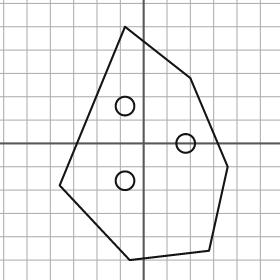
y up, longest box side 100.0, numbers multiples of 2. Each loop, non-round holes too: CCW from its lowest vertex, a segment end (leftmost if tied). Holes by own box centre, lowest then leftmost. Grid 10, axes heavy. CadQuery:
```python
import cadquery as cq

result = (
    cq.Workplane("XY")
    .moveTo(-6.0, -50.0)
    .lineTo(28.0, -46.0)
    .lineTo(36.0, -10.0)
    .lineTo(20.0, 28.0)
    .lineTo(-8.0, 50.0)
    .lineTo(-36.0, -18.0)
    .close()
    .moveTo(-8.0, -16.0)
    .circle(4.0)
    .moveTo(18.0, 0.0)
    .circle(4.0)
    .moveTo(-8.0, 16.0)
    .circle(4.0)
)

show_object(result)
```